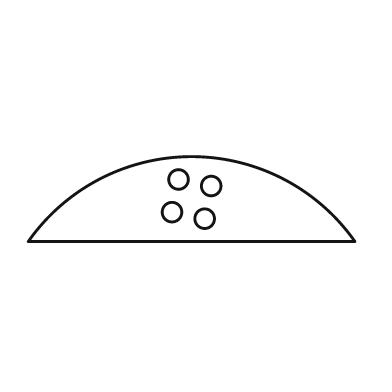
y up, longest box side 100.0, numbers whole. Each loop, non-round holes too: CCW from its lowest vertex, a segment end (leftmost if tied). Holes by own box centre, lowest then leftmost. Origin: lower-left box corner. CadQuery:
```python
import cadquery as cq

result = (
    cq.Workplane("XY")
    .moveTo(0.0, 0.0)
    .lineTo(100.0, 0.0)
    .threePointArc((50.0, 26.0), (0.0, 0.0))
    .close()
    .moveTo(54.0, 7.0)
    .circle(3.0)
    .moveTo(44.0, 9.0)
    .circle(3.0)
    .moveTo(56.0, 17.0)
    .circle(3.0)
    .moveTo(46.0, 19.0)
    .circle(3.0)
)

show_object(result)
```